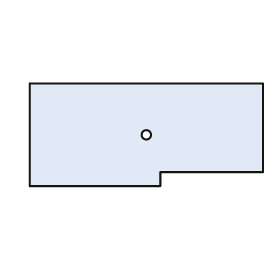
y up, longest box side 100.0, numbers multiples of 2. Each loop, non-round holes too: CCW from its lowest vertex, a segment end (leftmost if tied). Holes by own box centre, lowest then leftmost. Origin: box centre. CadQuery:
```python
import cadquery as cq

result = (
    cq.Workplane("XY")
    .moveTo(-50.0, -22.0)
    .lineTo(6.0, -22.0)
    .lineTo(6.0, -16.0)
    .lineTo(50.0, -16.0)
    .lineTo(50.0, 22.0)
    .lineTo(-50.0, 22.0)
    .close()
    .moveTo(0.0, 0.0)
    .circle(2.0)
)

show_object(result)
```